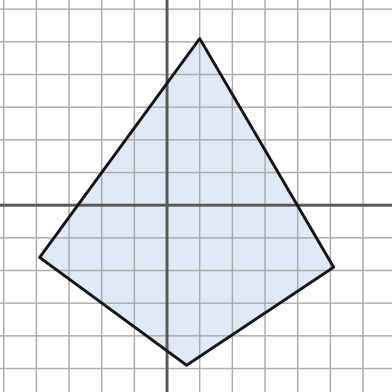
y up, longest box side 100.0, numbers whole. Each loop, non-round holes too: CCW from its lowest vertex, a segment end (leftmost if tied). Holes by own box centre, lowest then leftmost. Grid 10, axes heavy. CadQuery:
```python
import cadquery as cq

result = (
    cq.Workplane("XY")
    .moveTo(6.0, -49.0)
    .lineTo(51.0, -19.0)
    .lineTo(10.0, 51.0)
    .lineTo(-39.0, -16.0)
    .close()
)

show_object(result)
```